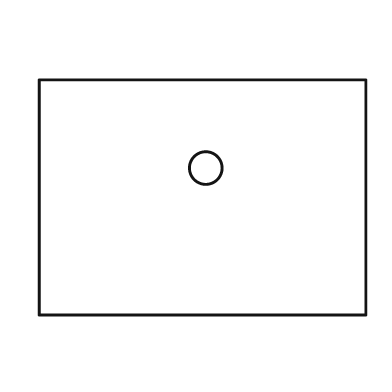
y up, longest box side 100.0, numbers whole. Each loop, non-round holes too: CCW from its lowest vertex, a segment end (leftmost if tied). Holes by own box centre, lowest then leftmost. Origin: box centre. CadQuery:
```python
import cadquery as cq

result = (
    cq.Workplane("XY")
    .moveTo(-50.0, -36.0)
    .lineTo(50.0, -36.0)
    .lineTo(50.0, 36.0)
    .lineTo(-50.0, 36.0)
    .close()
    .moveTo(1.0, 9.0)
    .circle(5.0)
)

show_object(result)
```